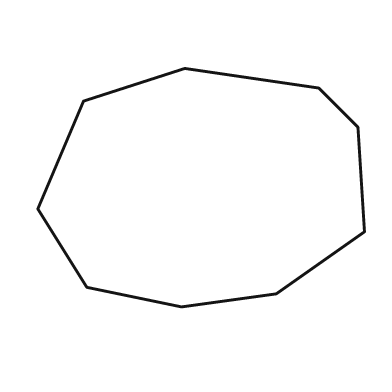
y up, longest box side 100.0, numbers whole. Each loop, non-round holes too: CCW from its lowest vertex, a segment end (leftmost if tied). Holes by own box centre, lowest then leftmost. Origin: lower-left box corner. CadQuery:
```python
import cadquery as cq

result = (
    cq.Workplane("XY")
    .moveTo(44.0, 0.0)
    .lineTo(73.0, 4.0)
    .lineTo(100.0, 23.0)
    .lineTo(98.0, 55.0)
    .lineTo(86.0, 67.0)
    .lineTo(45.0, 73.0)
    .lineTo(14.0, 63.0)
    .lineTo(0.0, 30.0)
    .lineTo(15.0, 6.0)
    .close()
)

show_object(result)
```